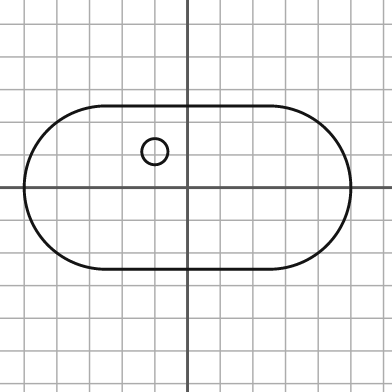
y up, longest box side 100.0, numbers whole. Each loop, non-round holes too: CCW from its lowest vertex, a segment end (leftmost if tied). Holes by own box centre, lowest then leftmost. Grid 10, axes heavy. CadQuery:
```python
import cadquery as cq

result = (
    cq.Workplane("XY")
    .moveTo(-25.0, -25.0)
    .lineTo(25.0, -25.0)
    .threePointArc((50.0, 0.0), (25.0, 25.0))
    .lineTo(-25.0, 25.0)
    .threePointArc((-50.0, 0.0), (-25.0, -25.0))
    .close()
    .moveTo(-10.0, 11.0)
    .circle(4.0)
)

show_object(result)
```